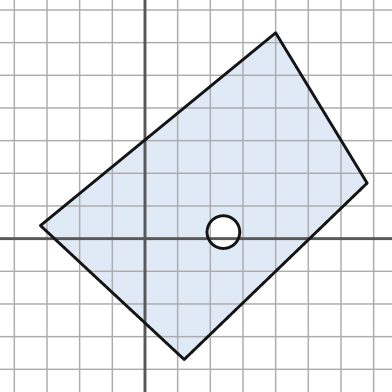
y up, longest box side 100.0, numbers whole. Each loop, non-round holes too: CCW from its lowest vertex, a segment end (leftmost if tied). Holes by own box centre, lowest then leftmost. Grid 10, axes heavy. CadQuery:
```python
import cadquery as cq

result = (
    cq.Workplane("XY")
    .moveTo(12.0, -37.0)
    .lineTo(68.0, 17.0)
    .lineTo(40.0, 63.0)
    .lineTo(-32.0, 4.0)
    .close()
    .moveTo(24.0, 2.0)
    .circle(5.0)
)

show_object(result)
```